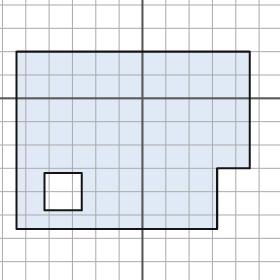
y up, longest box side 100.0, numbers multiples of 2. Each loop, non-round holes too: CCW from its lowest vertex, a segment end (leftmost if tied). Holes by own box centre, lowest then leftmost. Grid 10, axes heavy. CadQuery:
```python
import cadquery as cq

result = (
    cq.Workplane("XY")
    .moveTo(-54.0, -56.0)
    .lineTo(32.0, -56.0)
    .lineTo(32.0, -30.0)
    .lineTo(46.0, -30.0)
    .lineTo(46.0, 20.0)
    .lineTo(-54.0, 20.0)
    .close()
    .moveTo(-42.0, -48.0)
    .lineTo(-26.0, -48.0)
    .lineTo(-26.0, -32.0)
    .lineTo(-42.0, -32.0)
    .close()
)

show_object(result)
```